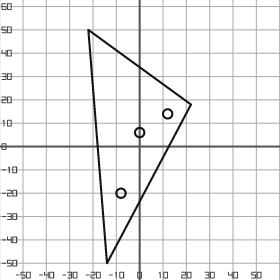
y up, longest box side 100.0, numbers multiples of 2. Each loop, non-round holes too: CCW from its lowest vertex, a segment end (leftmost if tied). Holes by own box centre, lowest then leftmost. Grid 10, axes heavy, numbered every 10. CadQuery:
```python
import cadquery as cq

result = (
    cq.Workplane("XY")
    .moveTo(-14.0, -50.0)
    .lineTo(22.0, 18.0)
    .lineTo(-22.0, 50.0)
    .close()
    .moveTo(-8.0, -20.0)
    .circle(2.0)
    .moveTo(0.0, 6.0)
    .circle(2.0)
    .moveTo(12.0, 14.0)
    .circle(2.0)
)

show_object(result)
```